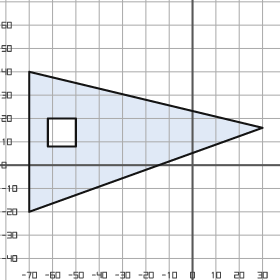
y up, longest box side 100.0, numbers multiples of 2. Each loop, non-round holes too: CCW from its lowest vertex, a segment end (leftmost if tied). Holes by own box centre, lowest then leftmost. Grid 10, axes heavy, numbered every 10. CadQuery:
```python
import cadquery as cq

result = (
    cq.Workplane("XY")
    .moveTo(-70.0, -20.0)
    .lineTo(30.0, 16.0)
    .lineTo(-70.0, 40.0)
    .close()
    .moveTo(-62.0, 8.0)
    .lineTo(-50.0, 8.0)
    .lineTo(-50.0, 20.0)
    .lineTo(-62.0, 20.0)
    .close()
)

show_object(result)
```